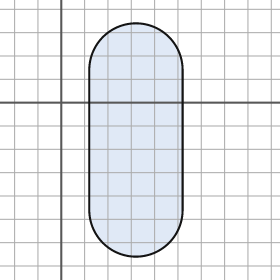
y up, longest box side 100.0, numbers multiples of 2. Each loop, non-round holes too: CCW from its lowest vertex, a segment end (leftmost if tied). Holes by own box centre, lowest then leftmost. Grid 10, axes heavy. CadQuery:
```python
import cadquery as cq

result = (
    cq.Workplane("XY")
    .moveTo(12.0, -46.0)
    .threePointArc((32.0, -66.0), (52.0, -46.0))
    .lineTo(52.0, 14.0)
    .threePointArc((32.0, 34.0), (12.0, 14.0))
    .close()
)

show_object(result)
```